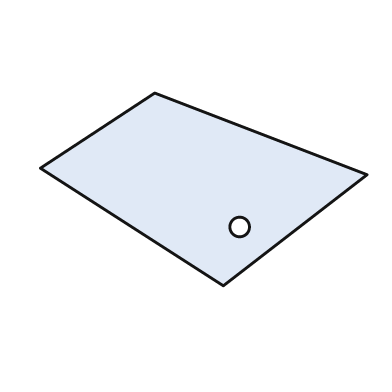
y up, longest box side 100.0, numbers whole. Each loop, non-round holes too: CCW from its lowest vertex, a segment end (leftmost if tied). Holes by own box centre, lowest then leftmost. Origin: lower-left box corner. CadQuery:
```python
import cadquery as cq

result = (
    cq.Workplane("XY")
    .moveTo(56.0, 0.0)
    .lineTo(100.0, 34.0)
    .lineTo(35.0, 59.0)
    .lineTo(0.0, 36.0)
    .close()
    .moveTo(61.0, 18.0)
    .circle(3.0)
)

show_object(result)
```